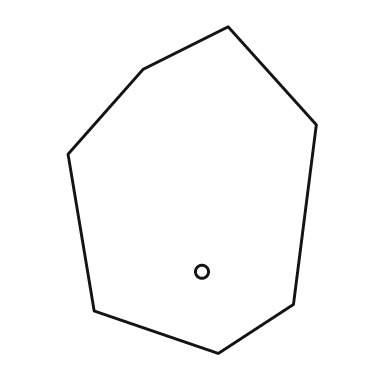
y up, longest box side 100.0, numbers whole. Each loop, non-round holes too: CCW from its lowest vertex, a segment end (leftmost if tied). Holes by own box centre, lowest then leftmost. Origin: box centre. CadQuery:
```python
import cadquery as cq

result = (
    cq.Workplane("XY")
    .moveTo(8.0, -50.0)
    .lineTo(31.0, -35.0)
    .lineTo(38.0, 20.0)
    .lineTo(11.0, 50.0)
    .lineTo(-15.0, 37.0)
    .lineTo(-38.0, 11.0)
    .lineTo(-30.0, -37.0)
    .close()
    .moveTo(3.0, -25.0)
    .circle(2.0)
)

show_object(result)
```